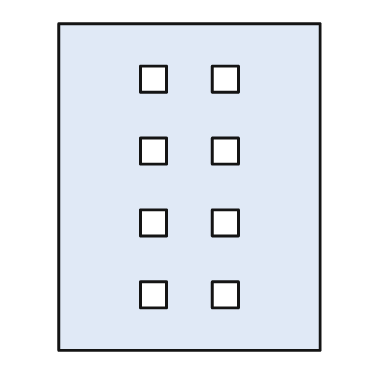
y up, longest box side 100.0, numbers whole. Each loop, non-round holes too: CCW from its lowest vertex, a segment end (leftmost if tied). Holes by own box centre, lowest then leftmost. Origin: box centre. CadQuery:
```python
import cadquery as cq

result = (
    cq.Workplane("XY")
    .moveTo(-40.0, -50.0)
    .lineTo(40.0, -50.0)
    .lineTo(40.0, 50.0)
    .lineTo(-40.0, 50.0)
    .close()
    .moveTo(-15.0, -37.0)
    .lineTo(-7.0, -37.0)
    .lineTo(-7.0, -29.0)
    .lineTo(-15.0, -29.0)
    .close()
    .moveTo(7.0, -37.0)
    .lineTo(15.0, -37.0)
    .lineTo(15.0, -29.0)
    .lineTo(7.0, -29.0)
    .close()
    .moveTo(-15.0, -15.0)
    .lineTo(-7.0, -15.0)
    .lineTo(-7.0, -7.0)
    .lineTo(-15.0, -7.0)
    .close()
    .moveTo(7.0, -15.0)
    .lineTo(15.0, -15.0)
    .lineTo(15.0, -7.0)
    .lineTo(7.0, -7.0)
    .close()
    .moveTo(-15.0, 7.0)
    .lineTo(-7.0, 7.0)
    .lineTo(-7.0, 15.0)
    .lineTo(-15.0, 15.0)
    .close()
    .moveTo(7.0, 7.0)
    .lineTo(15.0, 7.0)
    .lineTo(15.0, 15.0)
    .lineTo(7.0, 15.0)
    .close()
    .moveTo(-15.0, 29.0)
    .lineTo(-7.0, 29.0)
    .lineTo(-7.0, 37.0)
    .lineTo(-15.0, 37.0)
    .close()
    .moveTo(7.0, 29.0)
    .lineTo(15.0, 29.0)
    .lineTo(15.0, 37.0)
    .lineTo(7.0, 37.0)
    .close()
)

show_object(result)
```